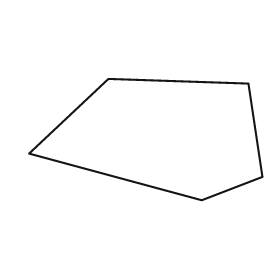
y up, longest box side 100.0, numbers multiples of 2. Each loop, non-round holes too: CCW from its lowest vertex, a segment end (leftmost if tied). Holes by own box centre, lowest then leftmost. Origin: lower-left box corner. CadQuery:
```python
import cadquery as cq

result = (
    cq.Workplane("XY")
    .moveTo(74.0, 0.0)
    .lineTo(100.0, 10.0)
    .lineTo(94.0, 50.0)
    .lineTo(34.0, 52.0)
    .lineTo(0.0, 20.0)
    .close()
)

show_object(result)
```